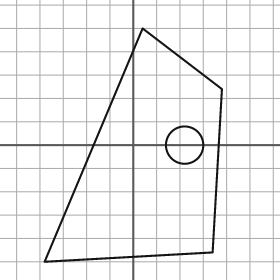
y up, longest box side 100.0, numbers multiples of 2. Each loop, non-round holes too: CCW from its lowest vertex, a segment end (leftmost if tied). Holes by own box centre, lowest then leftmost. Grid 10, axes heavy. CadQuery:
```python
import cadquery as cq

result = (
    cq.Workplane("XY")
    .moveTo(-38.0, -50.0)
    .lineTo(34.0, -46.0)
    .lineTo(38.0, 24.0)
    .lineTo(4.0, 50.0)
    .close()
    .moveTo(22.0, 0.0)
    .circle(8.0)
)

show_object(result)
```